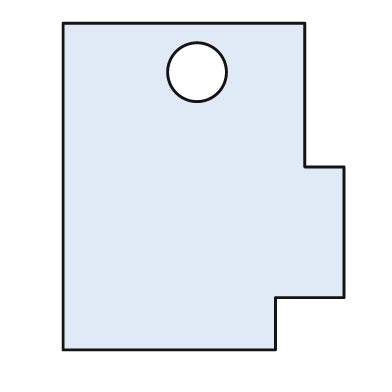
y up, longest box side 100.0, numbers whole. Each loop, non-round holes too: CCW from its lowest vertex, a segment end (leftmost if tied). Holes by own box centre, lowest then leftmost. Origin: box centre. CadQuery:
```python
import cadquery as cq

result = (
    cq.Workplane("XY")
    .moveTo(-43.0, -50.0)
    .lineTo(22.0, -50.0)
    .lineTo(22.0, -34.0)
    .lineTo(43.0, -34.0)
    .lineTo(43.0, 6.0)
    .lineTo(31.0, 6.0)
    .lineTo(31.0, 50.0)
    .lineTo(-43.0, 50.0)
    .close()
    .moveTo(-2.0, 35.0)
    .circle(9.0)
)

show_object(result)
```